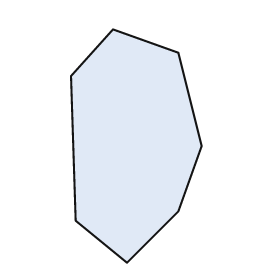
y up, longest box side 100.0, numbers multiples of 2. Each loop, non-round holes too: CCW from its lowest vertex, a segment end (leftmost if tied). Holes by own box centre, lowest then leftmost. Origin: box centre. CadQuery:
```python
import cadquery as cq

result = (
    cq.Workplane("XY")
    .moveTo(-4.0, -50.0)
    .lineTo(18.0, -28.0)
    .lineTo(28.0, 0.0)
    .lineTo(18.0, 40.0)
    .lineTo(-10.0, 50.0)
    .lineTo(-28.0, 30.0)
    .lineTo(-26.0, -32.0)
    .close()
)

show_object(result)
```